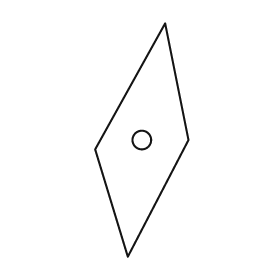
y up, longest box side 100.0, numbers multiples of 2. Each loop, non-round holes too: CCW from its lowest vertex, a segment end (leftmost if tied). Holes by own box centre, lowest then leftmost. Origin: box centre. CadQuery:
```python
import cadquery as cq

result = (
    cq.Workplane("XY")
    .moveTo(-6.0, -50.0)
    .lineTo(20.0, 0.0)
    .lineTo(10.0, 50.0)
    .lineTo(-20.0, -4.0)
    .close()
    .moveTo(0.0, 0.0)
    .circle(4.0)
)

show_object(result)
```